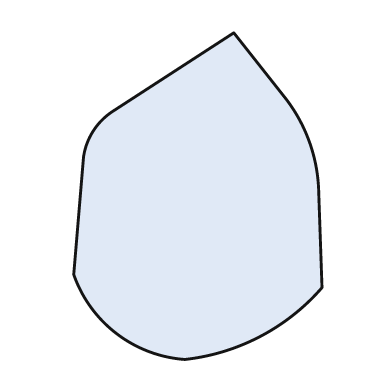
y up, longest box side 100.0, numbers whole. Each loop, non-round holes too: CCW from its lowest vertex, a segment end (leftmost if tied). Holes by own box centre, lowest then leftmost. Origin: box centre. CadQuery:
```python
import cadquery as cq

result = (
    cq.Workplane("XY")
    .moveTo(-4.0, -50.0)
    .threePointArc((19.0, -43.0), (38.0, -28.0))
    .lineTo(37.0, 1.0)
    .threePointArc((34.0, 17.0), (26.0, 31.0))
    .lineTo(11.0, 50.0)
    .lineTo(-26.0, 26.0)
    .threePointArc((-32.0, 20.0), (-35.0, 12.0))
    .lineTo(-38.0, -24.0)
    .threePointArc((-25.0, -42.0), (-4.0, -50.0))
    .close()
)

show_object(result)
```